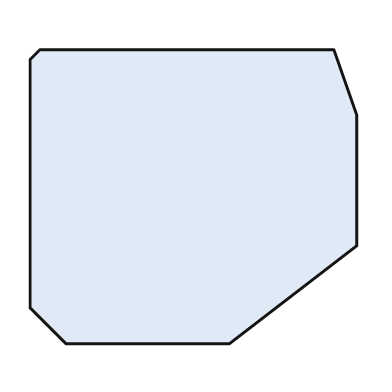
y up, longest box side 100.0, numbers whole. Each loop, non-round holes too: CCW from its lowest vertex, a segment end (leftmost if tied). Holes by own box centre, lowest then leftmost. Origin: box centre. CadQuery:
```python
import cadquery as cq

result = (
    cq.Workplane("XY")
    .moveTo(-39.0, -45.0)
    .lineTo(11.0, -45.0)
    .lineTo(50.0, -15.0)
    .lineTo(50.0, 25.0)
    .lineTo(43.0, 45.0)
    .lineTo(-47.0, 45.0)
    .lineTo(-50.0, 42.0)
    .lineTo(-50.0, -34.0)
    .close()
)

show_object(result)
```